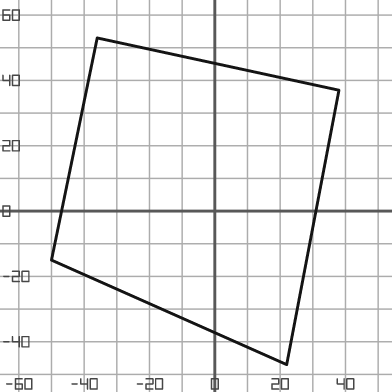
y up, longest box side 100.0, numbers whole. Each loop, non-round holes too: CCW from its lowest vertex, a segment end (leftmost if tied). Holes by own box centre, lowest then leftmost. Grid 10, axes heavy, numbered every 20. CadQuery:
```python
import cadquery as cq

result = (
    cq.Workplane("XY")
    .moveTo(22.0, -47.0)
    .lineTo(38.0, 37.0)
    .lineTo(-36.0, 53.0)
    .lineTo(-50.0, -15.0)
    .close()
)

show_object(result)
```